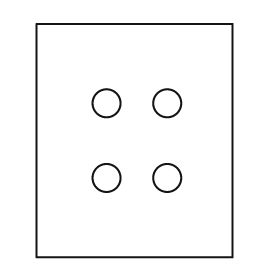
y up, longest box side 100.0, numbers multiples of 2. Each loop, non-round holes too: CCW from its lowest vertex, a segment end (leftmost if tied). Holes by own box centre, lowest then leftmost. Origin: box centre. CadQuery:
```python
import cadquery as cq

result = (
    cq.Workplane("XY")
    .moveTo(-42.0, -50.0)
    .lineTo(42.0, -50.0)
    .lineTo(42.0, 50.0)
    .lineTo(-42.0, 50.0)
    .close()
    .moveTo(-12.0, -16.0)
    .circle(6.0)
    .moveTo(14.0, -16.0)
    .circle(6.0)
    .moveTo(-12.0, 16.0)
    .circle(6.0)
    .moveTo(14.0, 16.0)
    .circle(6.0)
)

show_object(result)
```